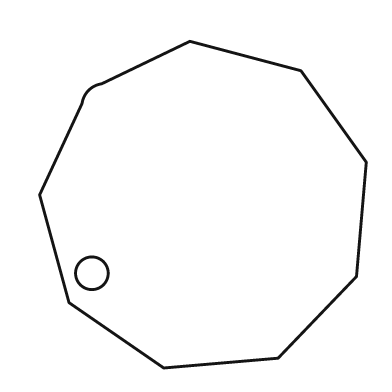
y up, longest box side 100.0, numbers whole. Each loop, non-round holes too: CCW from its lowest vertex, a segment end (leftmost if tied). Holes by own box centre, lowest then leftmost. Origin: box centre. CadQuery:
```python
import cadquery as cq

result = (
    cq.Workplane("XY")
    .moveTo(-12.0, -50.0)
    .lineTo(23.0, -47.0)
    .lineTo(47.0, -22.0)
    .lineTo(50.0, 13.0)
    .lineTo(30.0, 41.0)
    .lineTo(-4.0, 50.0)
    .lineTo(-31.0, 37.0)
    .threePointArc((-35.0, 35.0), (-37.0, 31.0))
    .lineTo(-50.0, 3.0)
    .lineTo(-41.0, -30.0)
    .close()
    .moveTo(-34.0, -21.0)
    .circle(5.0)
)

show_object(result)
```